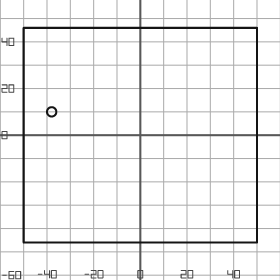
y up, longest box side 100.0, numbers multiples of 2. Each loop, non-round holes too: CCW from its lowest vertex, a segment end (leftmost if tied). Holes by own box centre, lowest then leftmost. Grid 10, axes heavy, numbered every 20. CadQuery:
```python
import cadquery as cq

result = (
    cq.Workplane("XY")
    .moveTo(-50.0, -46.0)
    .lineTo(50.0, -46.0)
    .lineTo(50.0, 46.0)
    .lineTo(-50.0, 46.0)
    .close()
    .moveTo(-38.0, 10.0)
    .circle(2.0)
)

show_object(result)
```